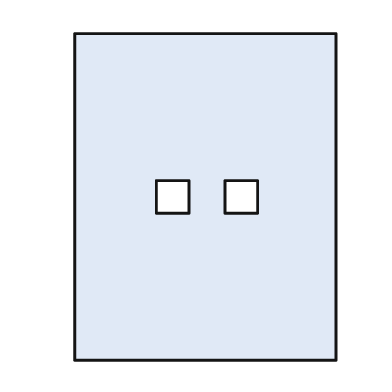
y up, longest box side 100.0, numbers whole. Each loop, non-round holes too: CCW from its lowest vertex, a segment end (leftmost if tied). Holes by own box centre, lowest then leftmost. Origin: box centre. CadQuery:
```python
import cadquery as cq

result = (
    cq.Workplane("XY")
    .moveTo(-40.0, -50.0)
    .lineTo(40.0, -50.0)
    .lineTo(40.0, 50.0)
    .lineTo(-40.0, 50.0)
    .close()
    .moveTo(-15.0, -5.0)
    .lineTo(-5.0, -5.0)
    .lineTo(-5.0, 5.0)
    .lineTo(-15.0, 5.0)
    .close()
    .moveTo(6.0, -5.0)
    .lineTo(16.0, -5.0)
    .lineTo(16.0, 5.0)
    .lineTo(6.0, 5.0)
    .close()
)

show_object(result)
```